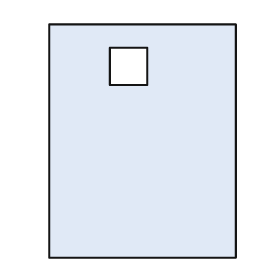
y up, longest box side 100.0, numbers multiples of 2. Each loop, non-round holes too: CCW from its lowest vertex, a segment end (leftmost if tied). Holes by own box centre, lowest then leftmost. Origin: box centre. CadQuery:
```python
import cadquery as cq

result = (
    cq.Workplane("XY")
    .moveTo(-40.0, -50.0)
    .lineTo(40.0, -50.0)
    .lineTo(40.0, 50.0)
    .lineTo(-40.0, 50.0)
    .close()
    .moveTo(-14.0, 24.0)
    .lineTo(2.0, 24.0)
    .lineTo(2.0, 40.0)
    .lineTo(-14.0, 40.0)
    .close()
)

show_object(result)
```